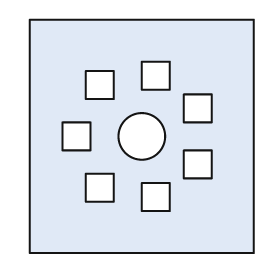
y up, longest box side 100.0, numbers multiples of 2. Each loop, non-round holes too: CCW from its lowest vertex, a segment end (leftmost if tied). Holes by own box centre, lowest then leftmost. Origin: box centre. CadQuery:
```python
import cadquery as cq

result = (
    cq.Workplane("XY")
    .moveTo(-48.0, -50.0)
    .lineTo(48.0, -50.0)
    .lineTo(48.0, 50.0)
    .lineTo(-48.0, 50.0)
    .close()
    .moveTo(0.0, -32.0)
    .lineTo(12.0, -32.0)
    .lineTo(12.0, -20.0)
    .lineTo(0.0, -20.0)
    .close()
    .moveTo(-24.0, -28.0)
    .lineTo(-12.0, -28.0)
    .lineTo(-12.0, -16.0)
    .lineTo(-24.0, -16.0)
    .close()
    .moveTo(18.0, -18.0)
    .lineTo(30.0, -18.0)
    .lineTo(30.0, -6.0)
    .lineTo(18.0, -6.0)
    .close()
    .moveTo(-34.0, -6.0)
    .lineTo(-22.0, -6.0)
    .lineTo(-22.0, 6.0)
    .lineTo(-34.0, 6.0)
    .close()
    .moveTo(0.0, 0.0)
    .circle(10.0)
    .moveTo(18.0, 6.0)
    .lineTo(30.0, 6.0)
    .lineTo(30.0, 18.0)
    .lineTo(18.0, 18.0)
    .close()
    .moveTo(-24.0, 16.0)
    .lineTo(-12.0, 16.0)
    .lineTo(-12.0, 28.0)
    .lineTo(-24.0, 28.0)
    .close()
    .moveTo(0.0, 20.0)
    .lineTo(12.0, 20.0)
    .lineTo(12.0, 32.0)
    .lineTo(0.0, 32.0)
    .close()
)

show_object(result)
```